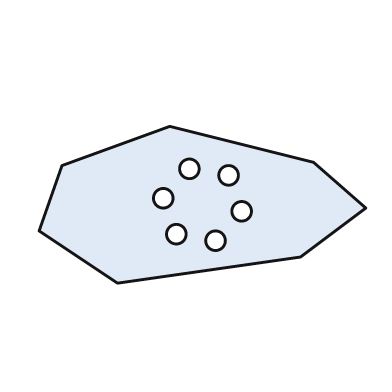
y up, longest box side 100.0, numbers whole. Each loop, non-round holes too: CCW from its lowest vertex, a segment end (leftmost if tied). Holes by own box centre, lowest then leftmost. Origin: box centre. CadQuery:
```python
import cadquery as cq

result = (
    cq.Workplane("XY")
    .moveTo(-26.0, -24.0)
    .lineTo(30.0, -16.0)
    .lineTo(50.0, -1.0)
    .lineTo(34.0, 13.0)
    .lineTo(-10.0, 24.0)
    .lineTo(-43.0, 12.0)
    .lineTo(-50.0, -8.0)
    .close()
    .moveTo(4.0, -11.0)
    .circle(3.0)
    .moveTo(-8.0, -9.0)
    .circle(3.0)
    .moveTo(12.0, -2.0)
    .circle(3.0)
    .moveTo(-12.0, 2.0)
    .circle(3.0)
    .moveTo(8.0, 9.0)
    .circle(3.0)
    .moveTo(-4.0, 11.0)
    .circle(3.0)
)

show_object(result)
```